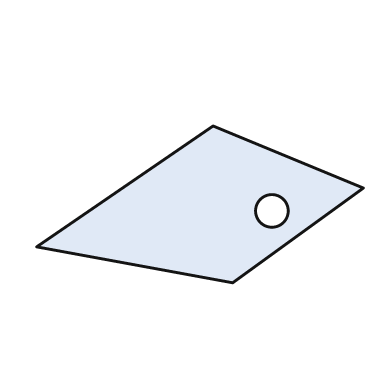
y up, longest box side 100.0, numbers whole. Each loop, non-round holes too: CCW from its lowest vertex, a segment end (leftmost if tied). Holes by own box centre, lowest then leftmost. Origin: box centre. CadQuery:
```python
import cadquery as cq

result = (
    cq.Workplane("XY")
    .moveTo(10.0, -24.0)
    .lineTo(50.0, 5.0)
    .lineTo(4.0, 24.0)
    .lineTo(-50.0, -13.0)
    .close()
    .moveTo(22.0, -2.0)
    .circle(5.0)
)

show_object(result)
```